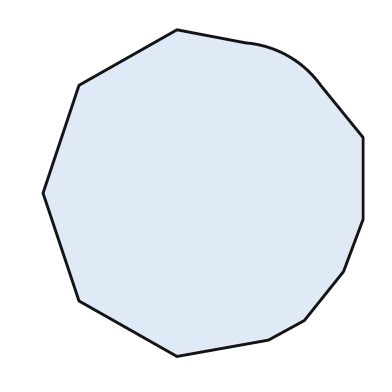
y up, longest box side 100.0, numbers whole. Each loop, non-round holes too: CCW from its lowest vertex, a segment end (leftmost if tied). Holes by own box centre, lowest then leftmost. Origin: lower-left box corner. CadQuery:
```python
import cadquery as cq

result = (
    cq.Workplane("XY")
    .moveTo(41.0, 0.0)
    .lineTo(69.0, 5.0)
    .lineTo(80.0, 11.0)
    .lineTo(92.0, 26.0)
    .lineTo(98.0, 42.0)
    .lineTo(98.0, 67.0)
    .lineTo(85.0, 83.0)
    .threePointArc((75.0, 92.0), (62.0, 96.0))
    .lineTo(41.0, 100.0)
    .lineTo(11.0, 83.0)
    .lineTo(0.0, 50.0)
    .lineTo(11.0, 17.0)
    .close()
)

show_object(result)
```